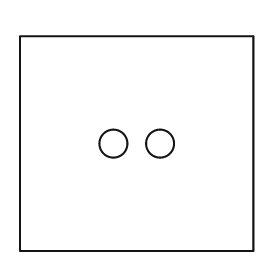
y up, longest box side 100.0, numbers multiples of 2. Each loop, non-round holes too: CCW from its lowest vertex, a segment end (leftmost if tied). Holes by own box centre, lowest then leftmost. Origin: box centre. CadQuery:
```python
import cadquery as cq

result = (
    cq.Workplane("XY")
    .moveTo(-50.0, -46.0)
    .lineTo(50.0, -46.0)
    .lineTo(50.0, 46.0)
    .lineTo(-50.0, 46.0)
    .close()
    .moveTo(-10.0, 0.0)
    .circle(6.0)
    .moveTo(10.0, 0.0)
    .circle(6.0)
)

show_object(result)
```